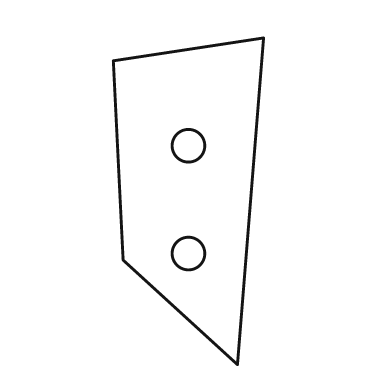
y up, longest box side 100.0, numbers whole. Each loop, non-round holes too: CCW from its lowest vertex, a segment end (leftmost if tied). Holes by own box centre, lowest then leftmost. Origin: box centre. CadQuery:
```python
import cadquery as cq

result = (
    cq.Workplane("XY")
    .moveTo(15.0, -50.0)
    .lineTo(23.0, 50.0)
    .lineTo(-23.0, 43.0)
    .lineTo(-20.0, -18.0)
    .close()
    .moveTo(0.0, -16.0)
    .circle(5.0)
    .moveTo(0.0, 17.0)
    .circle(5.0)
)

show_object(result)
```